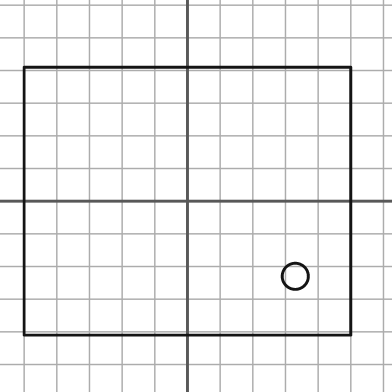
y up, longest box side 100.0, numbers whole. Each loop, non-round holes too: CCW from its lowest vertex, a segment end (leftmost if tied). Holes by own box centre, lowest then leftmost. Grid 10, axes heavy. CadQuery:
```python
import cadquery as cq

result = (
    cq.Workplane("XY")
    .moveTo(-50.0, -41.0)
    .lineTo(50.0, -41.0)
    .lineTo(50.0, 41.0)
    .lineTo(-50.0, 41.0)
    .close()
    .moveTo(33.0, -23.0)
    .circle(4.0)
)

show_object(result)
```